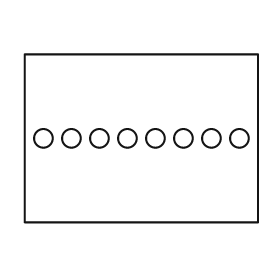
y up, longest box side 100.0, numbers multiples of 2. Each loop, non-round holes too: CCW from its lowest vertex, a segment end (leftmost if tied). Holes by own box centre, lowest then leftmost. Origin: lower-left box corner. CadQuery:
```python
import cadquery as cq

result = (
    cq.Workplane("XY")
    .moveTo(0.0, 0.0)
    .lineTo(100.0, 0.0)
    .lineTo(100.0, 72.0)
    .lineTo(0.0, 72.0)
    .close()
    .moveTo(8.0, 36.0)
    .circle(4.0)
    .moveTo(20.0, 36.0)
    .circle(4.0)
    .moveTo(32.0, 36.0)
    .circle(4.0)
    .moveTo(44.0, 36.0)
    .circle(4.0)
    .moveTo(56.0, 36.0)
    .circle(4.0)
    .moveTo(68.0, 36.0)
    .circle(4.0)
    .moveTo(80.0, 36.0)
    .circle(4.0)
    .moveTo(92.0, 36.0)
    .circle(4.0)
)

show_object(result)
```